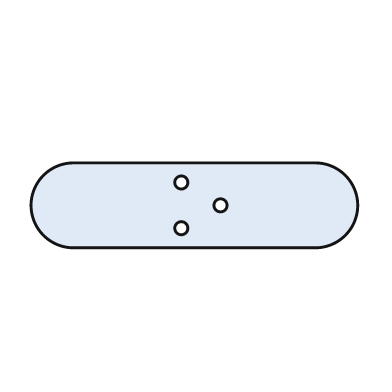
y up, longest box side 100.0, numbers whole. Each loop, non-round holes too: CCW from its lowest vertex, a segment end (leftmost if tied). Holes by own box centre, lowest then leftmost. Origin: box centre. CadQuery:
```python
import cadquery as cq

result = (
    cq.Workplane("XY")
    .moveTo(-37.0, -13.0)
    .lineTo(37.0, -13.0)
    .threePointArc((50.0, 0.0), (37.0, 13.0))
    .lineTo(-37.0, 13.0)
    .threePointArc((-50.0, 0.0), (-37.0, -13.0))
    .close()
    .moveTo(-4.0, -7.0)
    .circle(2.0)
    .moveTo(8.0, 0.0)
    .circle(2.0)
    .moveTo(-4.0, 7.0)
    .circle(2.0)
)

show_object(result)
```